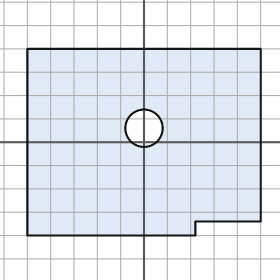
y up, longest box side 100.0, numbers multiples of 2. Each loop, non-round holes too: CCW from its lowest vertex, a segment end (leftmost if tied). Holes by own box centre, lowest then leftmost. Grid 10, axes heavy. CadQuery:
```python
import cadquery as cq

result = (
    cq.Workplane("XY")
    .moveTo(-50.0, -40.0)
    .lineTo(22.0, -40.0)
    .lineTo(22.0, -34.0)
    .lineTo(50.0, -34.0)
    .lineTo(50.0, 40.0)
    .lineTo(-50.0, 40.0)
    .close()
    .moveTo(0.0, 6.0)
    .circle(8.0)
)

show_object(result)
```